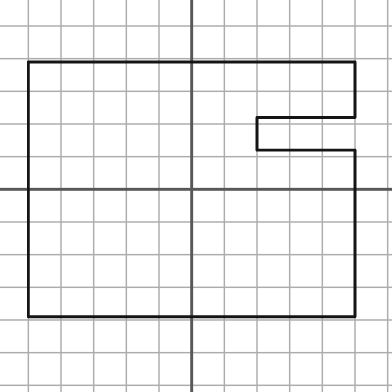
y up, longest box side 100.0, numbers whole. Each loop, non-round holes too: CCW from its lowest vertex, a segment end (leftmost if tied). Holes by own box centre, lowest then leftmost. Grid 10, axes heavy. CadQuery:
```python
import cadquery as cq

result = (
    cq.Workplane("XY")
    .moveTo(-50.0, -39.0)
    .lineTo(50.0, -39.0)
    .lineTo(50.0, 12.0)
    .lineTo(20.0, 12.0)
    .lineTo(20.0, 22.0)
    .lineTo(50.0, 22.0)
    .lineTo(50.0, 39.0)
    .lineTo(-50.0, 39.0)
    .close()
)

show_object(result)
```